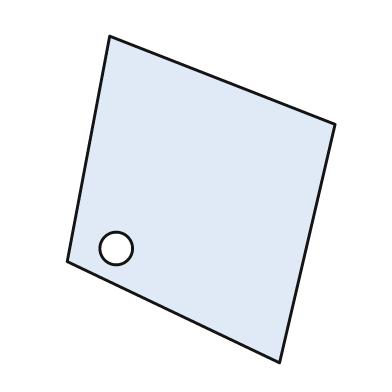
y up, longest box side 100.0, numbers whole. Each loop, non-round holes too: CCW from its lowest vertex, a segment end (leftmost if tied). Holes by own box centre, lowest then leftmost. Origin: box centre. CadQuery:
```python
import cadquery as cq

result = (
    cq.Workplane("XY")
    .moveTo(24.0, -50.0)
    .lineTo(41.0, 23.0)
    .lineTo(-28.0, 50.0)
    .lineTo(-41.0, -19.0)
    .close()
    .moveTo(-26.0, -15.0)
    .circle(5.0)
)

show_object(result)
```